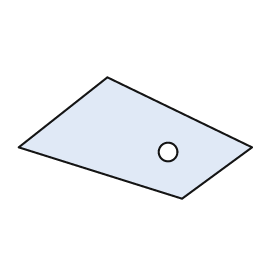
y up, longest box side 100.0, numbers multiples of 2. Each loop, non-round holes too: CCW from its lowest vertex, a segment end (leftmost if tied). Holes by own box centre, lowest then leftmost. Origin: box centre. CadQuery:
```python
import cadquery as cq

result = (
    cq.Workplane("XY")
    .moveTo(20.0, -26.0)
    .lineTo(50.0, -4.0)
    .lineTo(-12.0, 26.0)
    .lineTo(-50.0, -4.0)
    .close()
    .moveTo(14.0, -6.0)
    .circle(4.0)
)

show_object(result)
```